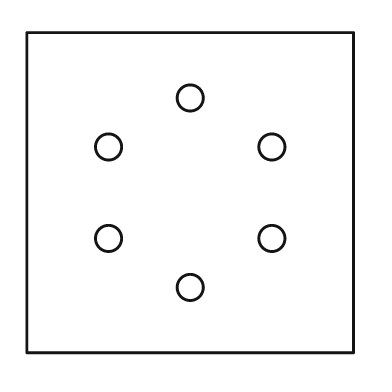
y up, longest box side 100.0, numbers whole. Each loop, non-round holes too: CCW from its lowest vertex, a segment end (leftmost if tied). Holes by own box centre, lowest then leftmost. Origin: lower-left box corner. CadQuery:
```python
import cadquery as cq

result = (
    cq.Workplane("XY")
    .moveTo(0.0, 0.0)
    .lineTo(100.0, 0.0)
    .lineTo(100.0, 98.0)
    .lineTo(0.0, 98.0)
    .close()
    .moveTo(50.0, 20.0)
    .circle(4.0)
    .moveTo(25.0, 35.0)
    .circle(4.0)
    .moveTo(75.0, 35.0)
    .circle(4.0)
    .moveTo(25.0, 63.0)
    .circle(4.0)
    .moveTo(75.0, 63.0)
    .circle(4.0)
    .moveTo(50.0, 78.0)
    .circle(4.0)
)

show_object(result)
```